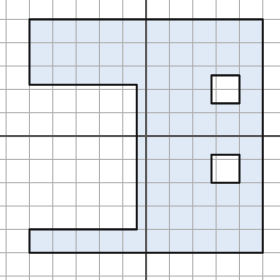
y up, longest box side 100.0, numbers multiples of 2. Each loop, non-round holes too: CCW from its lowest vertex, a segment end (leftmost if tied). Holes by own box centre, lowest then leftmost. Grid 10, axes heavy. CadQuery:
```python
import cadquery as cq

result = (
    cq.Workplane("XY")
    .moveTo(-50.0, -50.0)
    .lineTo(50.0, -50.0)
    .lineTo(50.0, 50.0)
    .lineTo(-50.0, 50.0)
    .lineTo(-50.0, 22.0)
    .lineTo(-4.0, 22.0)
    .lineTo(-4.0, -40.0)
    .lineTo(-50.0, -40.0)
    .close()
    .moveTo(28.0, -20.0)
    .lineTo(40.0, -20.0)
    .lineTo(40.0, -8.0)
    .lineTo(28.0, -8.0)
    .close()
    .moveTo(28.0, 14.0)
    .lineTo(40.0, 14.0)
    .lineTo(40.0, 26.0)
    .lineTo(28.0, 26.0)
    .close()
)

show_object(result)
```